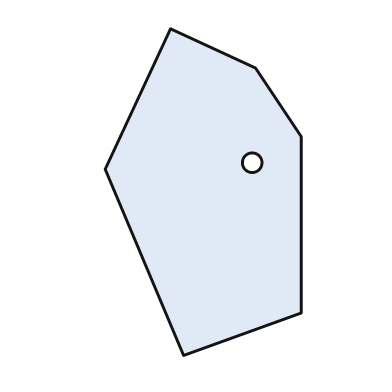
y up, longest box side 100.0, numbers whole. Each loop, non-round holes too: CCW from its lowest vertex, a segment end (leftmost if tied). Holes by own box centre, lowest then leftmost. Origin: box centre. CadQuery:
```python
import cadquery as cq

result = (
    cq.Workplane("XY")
    .moveTo(-6.0, -50.0)
    .lineTo(30.0, -37.0)
    .lineTo(30.0, 17.0)
    .lineTo(16.0, 38.0)
    .lineTo(-10.0, 50.0)
    .lineTo(-30.0, 7.0)
    .close()
    .moveTo(15.0, 9.0)
    .circle(3.0)
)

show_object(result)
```